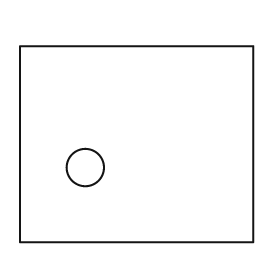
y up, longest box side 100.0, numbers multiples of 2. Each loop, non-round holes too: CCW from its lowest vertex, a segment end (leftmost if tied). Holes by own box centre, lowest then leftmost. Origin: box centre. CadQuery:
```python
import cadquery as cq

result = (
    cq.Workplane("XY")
    .moveTo(-50.0, -42.0)
    .lineTo(50.0, -42.0)
    .lineTo(50.0, 42.0)
    .lineTo(-50.0, 42.0)
    .close()
    .moveTo(-22.0, -10.0)
    .circle(8.0)
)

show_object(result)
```